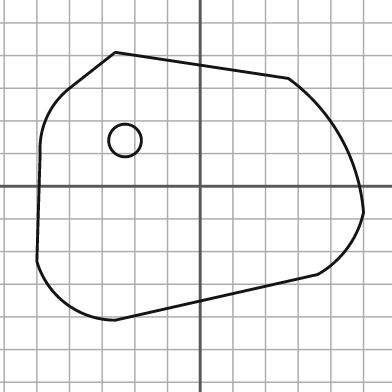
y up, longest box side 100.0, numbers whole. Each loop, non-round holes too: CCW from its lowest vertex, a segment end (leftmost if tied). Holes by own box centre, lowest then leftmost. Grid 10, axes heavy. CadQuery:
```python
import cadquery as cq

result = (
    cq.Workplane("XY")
    .moveTo(-26.0, -41.0)
    .lineTo(36.0, -27.0)
    .threePointArc((45.0, -19.0), (50.0, -8.0))
    .threePointArc((43.0, 15.0), (27.0, 33.0))
    .lineTo(-26.0, 41.0)
    .lineTo(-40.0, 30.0)
    .threePointArc((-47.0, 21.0), (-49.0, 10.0))
    .lineTo(-50.0, -23.0)
    .threePointArc((-41.0, -36.0), (-26.0, -41.0))
    .close()
    .moveTo(-23.0, 14.0)
    .circle(5.0)
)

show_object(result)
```